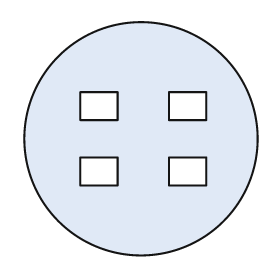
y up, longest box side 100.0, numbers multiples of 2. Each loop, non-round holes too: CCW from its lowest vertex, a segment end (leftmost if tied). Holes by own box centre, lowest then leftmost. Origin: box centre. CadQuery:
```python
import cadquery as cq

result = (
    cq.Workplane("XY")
    .moveTo(0.0, 0.0)
    .circle(50.0)
    .moveTo(-26.0, -20.0)
    .lineTo(-10.0, -20.0)
    .lineTo(-10.0, -8.0)
    .lineTo(-26.0, -8.0)
    .close()
    .moveTo(12.0, -20.0)
    .lineTo(28.0, -20.0)
    .lineTo(28.0, -8.0)
    .lineTo(12.0, -8.0)
    .close()
    .moveTo(-26.0, 8.0)
    .lineTo(-10.0, 8.0)
    .lineTo(-10.0, 20.0)
    .lineTo(-26.0, 20.0)
    .close()
    .moveTo(12.0, 8.0)
    .lineTo(28.0, 8.0)
    .lineTo(28.0, 20.0)
    .lineTo(12.0, 20.0)
    .close()
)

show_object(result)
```